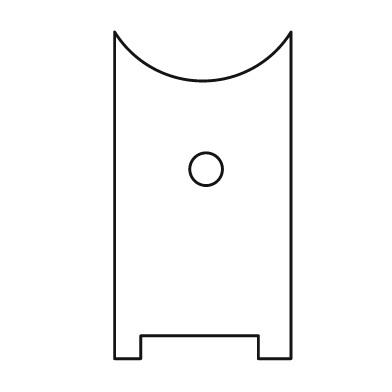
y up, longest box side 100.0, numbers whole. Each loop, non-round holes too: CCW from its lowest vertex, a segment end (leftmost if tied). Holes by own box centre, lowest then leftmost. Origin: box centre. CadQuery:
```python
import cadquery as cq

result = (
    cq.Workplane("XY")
    .moveTo(-27.0, -50.0)
    .lineTo(-19.0, -50.0)
    .lineTo(-19.0, -43.0)
    .lineTo(17.0, -43.0)
    .lineTo(17.0, -50.0)
    .lineTo(27.0, -50.0)
    .lineTo(27.0, 50.0)
    .threePointArc((0.0, 35.0), (-27.0, 50.0))
    .close()
    .moveTo(1.0, 8.0)
    .circle(5.0)
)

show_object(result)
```